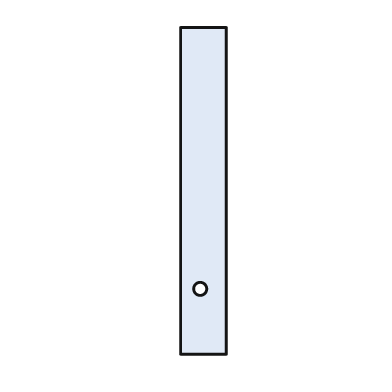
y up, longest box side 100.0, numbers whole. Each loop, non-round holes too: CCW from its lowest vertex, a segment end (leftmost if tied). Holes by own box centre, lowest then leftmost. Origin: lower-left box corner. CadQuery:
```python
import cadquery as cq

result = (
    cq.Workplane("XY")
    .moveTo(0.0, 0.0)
    .lineTo(14.0, 0.0)
    .lineTo(14.0, 100.0)
    .lineTo(0.0, 100.0)
    .close()
    .moveTo(6.0, 20.0)
    .circle(2.0)
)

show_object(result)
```